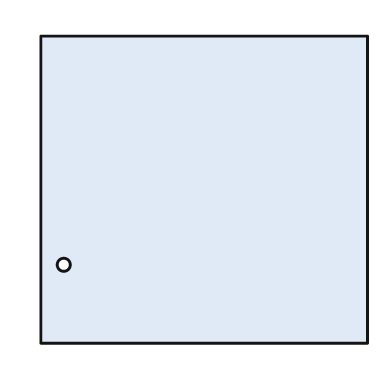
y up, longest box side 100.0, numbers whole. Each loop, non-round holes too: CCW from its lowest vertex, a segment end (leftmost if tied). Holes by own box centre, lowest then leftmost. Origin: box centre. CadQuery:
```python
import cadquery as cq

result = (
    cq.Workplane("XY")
    .moveTo(-50.0, -47.0)
    .lineTo(50.0, -47.0)
    .lineTo(50.0, 47.0)
    .lineTo(-50.0, 47.0)
    .close()
    .moveTo(-43.0, -23.0)
    .circle(2.0)
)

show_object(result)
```